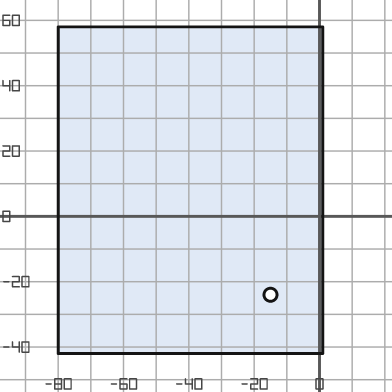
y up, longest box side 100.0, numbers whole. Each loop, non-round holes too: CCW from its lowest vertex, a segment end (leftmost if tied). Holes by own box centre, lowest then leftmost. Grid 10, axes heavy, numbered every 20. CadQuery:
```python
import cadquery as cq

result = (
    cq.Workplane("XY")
    .moveTo(-80.0, -42.0)
    .lineTo(1.0, -42.0)
    .lineTo(1.0, 58.0)
    .lineTo(-80.0, 58.0)
    .close()
    .moveTo(-15.0, -24.0)
    .circle(2.0)
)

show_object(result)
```